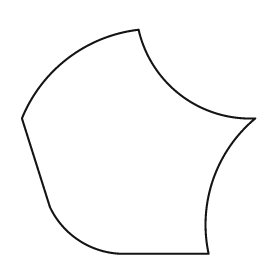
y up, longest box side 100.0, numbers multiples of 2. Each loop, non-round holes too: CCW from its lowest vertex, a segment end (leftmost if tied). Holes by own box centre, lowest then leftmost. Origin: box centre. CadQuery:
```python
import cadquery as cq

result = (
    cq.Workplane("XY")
    .moveTo(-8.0, -48.0)
    .lineTo(30.0, -48.0)
    .threePointArc((32.0, -16.0), (50.0, 10.0))
    .threePointArc((18.0, 20.0), (0.0, 48.0))
    .threePointArc((-30.0, 36.0), (-50.0, 10.0))
    .lineTo(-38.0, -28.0)
    .threePointArc((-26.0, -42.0), (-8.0, -48.0))
    .close()
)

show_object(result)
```